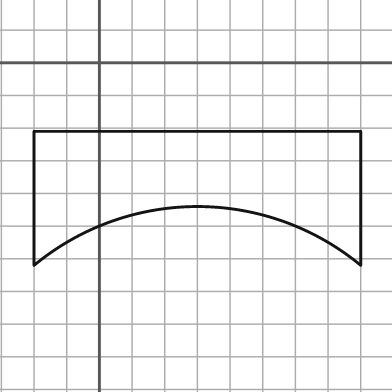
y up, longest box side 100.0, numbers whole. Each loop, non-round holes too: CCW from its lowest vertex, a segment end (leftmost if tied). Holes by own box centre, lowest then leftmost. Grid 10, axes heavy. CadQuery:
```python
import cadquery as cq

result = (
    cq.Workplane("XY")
    .moveTo(-20.0, -62.0)
    .threePointArc((30.0, -44.0), (80.0, -62.0))
    .lineTo(80.0, -21.0)
    .lineTo(-20.0, -21.0)
    .close()
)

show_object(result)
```